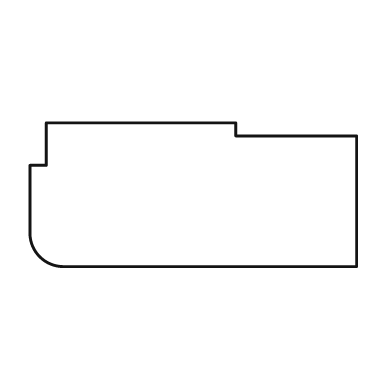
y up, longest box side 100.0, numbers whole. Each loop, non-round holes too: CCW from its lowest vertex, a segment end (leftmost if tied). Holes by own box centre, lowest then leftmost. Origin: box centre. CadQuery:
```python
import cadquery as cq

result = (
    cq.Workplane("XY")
    .moveTo(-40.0, -22.0)
    .lineTo(50.0, -22.0)
    .lineTo(50.0, 18.0)
    .lineTo(13.0, 18.0)
    .lineTo(13.0, 22.0)
    .lineTo(-45.0, 22.0)
    .lineTo(-45.0, 9.0)
    .lineTo(-50.0, 9.0)
    .lineTo(-50.0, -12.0)
    .threePointArc((-47.0, -19.0), (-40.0, -22.0))
    .close()
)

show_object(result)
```